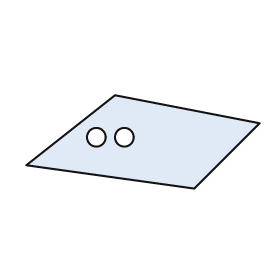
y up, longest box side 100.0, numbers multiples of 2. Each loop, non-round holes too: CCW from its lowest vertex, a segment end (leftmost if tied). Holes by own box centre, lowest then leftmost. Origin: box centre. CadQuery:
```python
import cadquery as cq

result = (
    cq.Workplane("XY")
    .moveTo(22.0, -20.0)
    .lineTo(50.0, 8.0)
    .lineTo(-12.0, 20.0)
    .lineTo(-50.0, -10.0)
    .close()
    .moveTo(-20.0, 2.0)
    .circle(4.0)
    .moveTo(-8.0, 2.0)
    .circle(4.0)
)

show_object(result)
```